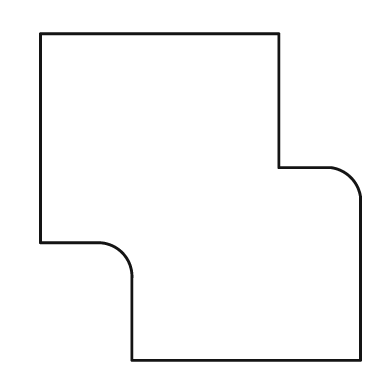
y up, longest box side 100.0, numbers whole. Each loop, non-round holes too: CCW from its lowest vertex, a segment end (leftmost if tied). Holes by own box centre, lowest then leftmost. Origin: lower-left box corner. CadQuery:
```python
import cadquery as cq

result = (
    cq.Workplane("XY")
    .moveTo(28.0, 0.0)
    .lineTo(98.0, 0.0)
    .lineTo(98.0, 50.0)
    .threePointArc((95.0, 56.0), (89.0, 59.0))
    .lineTo(73.0, 59.0)
    .lineTo(73.0, 100.0)
    .lineTo(0.0, 100.0)
    .lineTo(0.0, 36.0)
    .lineTo(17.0, 36.0)
    .threePointArc((25.0, 33.0), (28.0, 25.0))
    .close()
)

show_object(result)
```